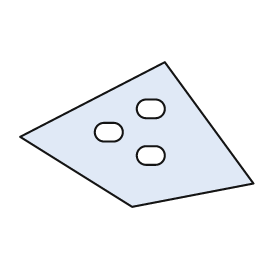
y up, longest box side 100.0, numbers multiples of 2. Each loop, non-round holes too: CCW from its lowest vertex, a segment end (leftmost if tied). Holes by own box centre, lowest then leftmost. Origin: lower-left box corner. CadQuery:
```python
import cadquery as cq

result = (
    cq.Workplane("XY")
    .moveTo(48.0, 0.0)
    .lineTo(100.0, 10.0)
    .lineTo(62.0, 62.0)
    .lineTo(0.0, 30.0)
    .close()
    .moveTo(54.0, 18.0)
    .lineTo(58.0, 18.0)
    .threePointArc((62.0, 22.0), (58.0, 26.0))
    .lineTo(54.0, 26.0)
    .threePointArc((50.0, 22.0), (54.0, 18.0))
    .close()
    .moveTo(36.0, 28.0)
    .lineTo(40.0, 28.0)
    .threePointArc((44.0, 32.0), (40.0, 36.0))
    .lineTo(36.0, 36.0)
    .threePointArc((32.0, 32.0), (36.0, 28.0))
    .close()
    .moveTo(54.0, 38.0)
    .lineTo(58.0, 38.0)
    .threePointArc((62.0, 42.0), (58.0, 46.0))
    .lineTo(54.0, 46.0)
    .threePointArc((50.0, 42.0), (54.0, 38.0))
    .close()
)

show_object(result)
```